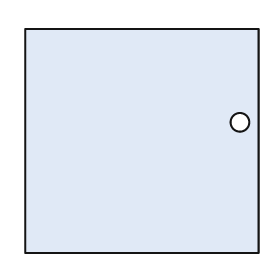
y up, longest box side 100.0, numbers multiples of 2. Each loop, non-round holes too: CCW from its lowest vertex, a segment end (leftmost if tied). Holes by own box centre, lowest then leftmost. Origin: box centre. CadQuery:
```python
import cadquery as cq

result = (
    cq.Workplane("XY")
    .moveTo(-50.0, -48.0)
    .lineTo(50.0, -48.0)
    .lineTo(50.0, 48.0)
    .lineTo(-50.0, 48.0)
    .close()
    .moveTo(42.0, 8.0)
    .circle(4.0)
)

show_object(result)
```